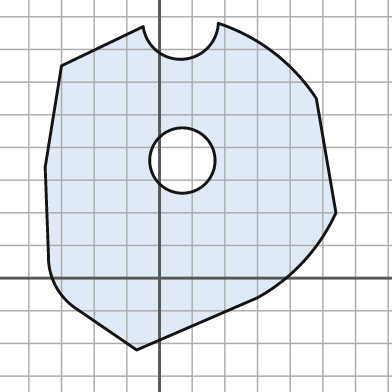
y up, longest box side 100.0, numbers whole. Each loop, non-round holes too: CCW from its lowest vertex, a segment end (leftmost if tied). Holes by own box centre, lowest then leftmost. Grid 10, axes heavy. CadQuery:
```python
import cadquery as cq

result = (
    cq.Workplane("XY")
    .moveTo(-7.0, -22.0)
    .lineTo(30.0, -6.0)
    .threePointArc((44.0, 5.0), (54.0, 20.0))
    .lineTo(48.0, 55.0)
    .threePointArc((35.0, 69.0), (18.0, 78.0))
    .threePointArc((7.0, 67.0), (-5.0, 77.0))
    .lineTo(-30.0, 65.0)
    .lineTo(-35.0, 34.0)
    .lineTo(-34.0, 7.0)
    .threePointArc((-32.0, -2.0), (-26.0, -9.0))
    .close()
    .moveTo(7.0, 36.0)
    .circle(10.0)
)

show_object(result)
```